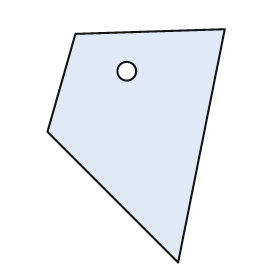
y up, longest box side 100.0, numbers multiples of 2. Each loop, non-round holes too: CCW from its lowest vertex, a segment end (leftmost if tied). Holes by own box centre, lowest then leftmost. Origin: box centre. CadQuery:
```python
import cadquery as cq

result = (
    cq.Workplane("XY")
    .moveTo(18.0, -50.0)
    .lineTo(38.0, 50.0)
    .lineTo(-26.0, 48.0)
    .lineTo(-38.0, 6.0)
    .close()
    .moveTo(-4.0, 32.0)
    .circle(4.0)
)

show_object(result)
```